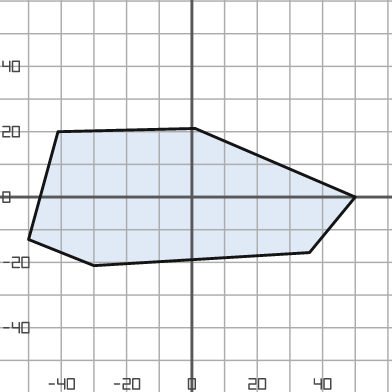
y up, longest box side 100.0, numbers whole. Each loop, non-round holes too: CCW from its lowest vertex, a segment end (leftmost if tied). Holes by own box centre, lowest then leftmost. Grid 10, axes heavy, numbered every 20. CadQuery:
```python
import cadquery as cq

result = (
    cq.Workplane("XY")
    .moveTo(-30.0, -21.0)
    .lineTo(36.0, -17.0)
    .lineTo(50.0, 0.0)
    .lineTo(1.0, 21.0)
    .lineTo(-41.0, 20.0)
    .lineTo(-50.0, -13.0)
    .close()
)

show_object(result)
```